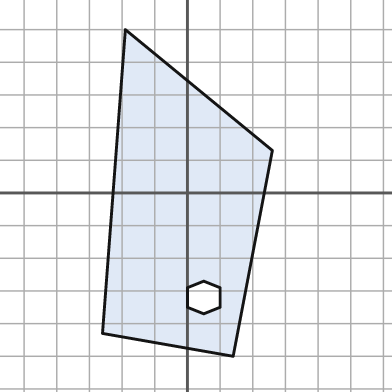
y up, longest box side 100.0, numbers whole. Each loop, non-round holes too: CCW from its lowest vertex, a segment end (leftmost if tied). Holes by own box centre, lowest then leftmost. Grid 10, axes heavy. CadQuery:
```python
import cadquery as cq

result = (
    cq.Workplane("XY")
    .moveTo(14.0, -50.0)
    .lineTo(26.0, 13.0)
    .lineTo(-19.0, 50.0)
    .lineTo(-26.0, -43.0)
    .close()
    .moveTo(5.0, -37.0)
    .lineTo(10.0, -35.0)
    .lineTo(10.0, -29.0)
    .lineTo(5.0, -27.0)
    .lineTo(0.0, -29.0)
    .lineTo(0.0, -35.0)
    .close()
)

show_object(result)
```